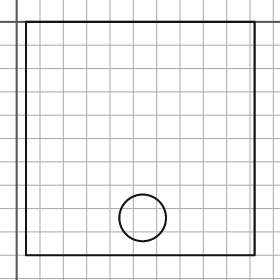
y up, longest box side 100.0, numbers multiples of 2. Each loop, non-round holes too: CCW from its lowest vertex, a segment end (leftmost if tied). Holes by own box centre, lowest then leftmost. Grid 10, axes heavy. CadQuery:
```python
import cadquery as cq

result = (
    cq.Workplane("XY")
    .moveTo(4.0, -100.0)
    .lineTo(102.0, -100.0)
    .lineTo(102.0, 0.0)
    .lineTo(4.0, 0.0)
    .close()
    .moveTo(54.0, -84.0)
    .circle(10.0)
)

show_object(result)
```